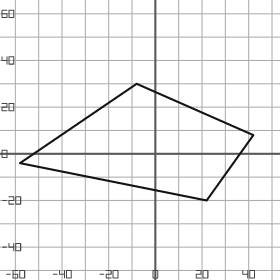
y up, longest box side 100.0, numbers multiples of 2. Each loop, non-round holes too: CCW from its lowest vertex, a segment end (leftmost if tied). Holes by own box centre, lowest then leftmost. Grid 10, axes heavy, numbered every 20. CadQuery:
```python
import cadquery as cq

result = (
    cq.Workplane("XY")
    .moveTo(22.0, -20.0)
    .lineTo(42.0, 8.0)
    .lineTo(-8.0, 30.0)
    .lineTo(-58.0, -4.0)
    .close()
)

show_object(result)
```